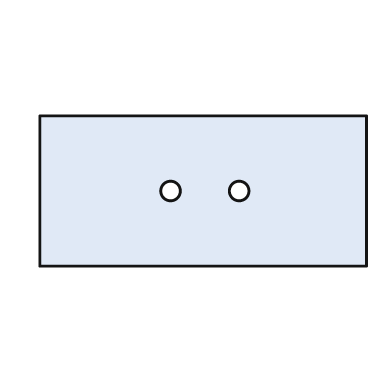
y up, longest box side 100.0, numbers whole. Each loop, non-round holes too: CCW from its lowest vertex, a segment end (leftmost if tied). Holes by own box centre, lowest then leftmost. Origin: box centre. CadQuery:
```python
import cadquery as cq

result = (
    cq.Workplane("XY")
    .moveTo(-50.0, -23.0)
    .lineTo(50.0, -23.0)
    .lineTo(50.0, 23.0)
    .lineTo(-50.0, 23.0)
    .close()
    .moveTo(-10.0, 0.0)
    .circle(3.0)
    .moveTo(11.0, 0.0)
    .circle(3.0)
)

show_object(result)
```